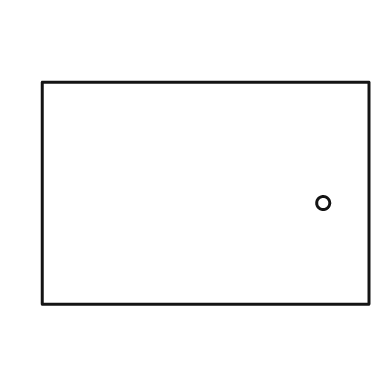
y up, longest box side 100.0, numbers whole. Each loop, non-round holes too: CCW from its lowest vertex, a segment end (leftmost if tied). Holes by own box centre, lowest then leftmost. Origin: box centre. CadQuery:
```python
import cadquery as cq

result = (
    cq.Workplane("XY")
    .moveTo(-50.0, -34.0)
    .lineTo(50.0, -34.0)
    .lineTo(50.0, 34.0)
    .lineTo(-50.0, 34.0)
    .close()
    .moveTo(36.0, -3.0)
    .circle(2.0)
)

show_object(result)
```